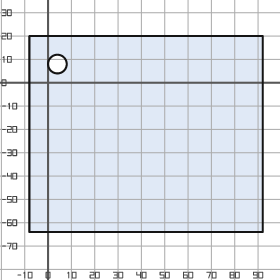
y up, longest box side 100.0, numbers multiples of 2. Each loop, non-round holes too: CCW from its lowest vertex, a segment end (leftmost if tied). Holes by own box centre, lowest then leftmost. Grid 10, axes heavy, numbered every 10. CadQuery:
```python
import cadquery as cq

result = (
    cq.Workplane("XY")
    .moveTo(-8.0, -64.0)
    .lineTo(92.0, -64.0)
    .lineTo(92.0, 20.0)
    .lineTo(-8.0, 20.0)
    .close()
    .moveTo(4.0, 8.0)
    .circle(4.0)
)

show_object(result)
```